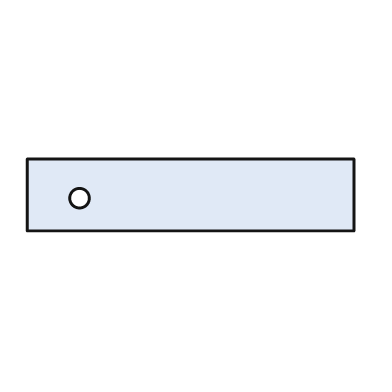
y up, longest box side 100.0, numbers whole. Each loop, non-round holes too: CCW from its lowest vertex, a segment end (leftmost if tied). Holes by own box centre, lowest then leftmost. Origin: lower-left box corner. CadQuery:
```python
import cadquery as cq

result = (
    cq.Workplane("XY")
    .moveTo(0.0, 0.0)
    .lineTo(100.0, 0.0)
    .lineTo(100.0, 22.0)
    .lineTo(0.0, 22.0)
    .close()
    .moveTo(16.0, 10.0)
    .circle(3.0)
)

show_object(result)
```